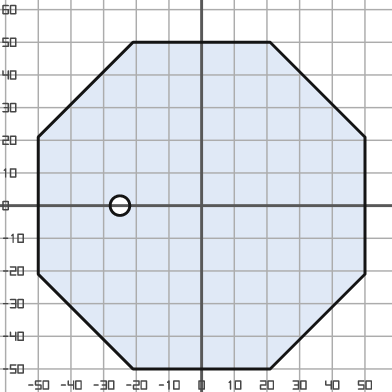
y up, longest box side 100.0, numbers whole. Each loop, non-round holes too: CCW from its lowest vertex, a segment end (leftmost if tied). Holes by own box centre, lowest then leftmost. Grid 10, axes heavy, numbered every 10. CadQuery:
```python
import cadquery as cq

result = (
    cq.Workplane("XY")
    .moveTo(-21.0, -50.0)
    .lineTo(21.0, -50.0)
    .lineTo(50.0, -21.0)
    .lineTo(50.0, 21.0)
    .lineTo(21.0, 50.0)
    .lineTo(-21.0, 50.0)
    .lineTo(-50.0, 21.0)
    .lineTo(-50.0, -21.0)
    .close()
    .moveTo(-25.0, 0.0)
    .circle(3.0)
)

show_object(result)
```